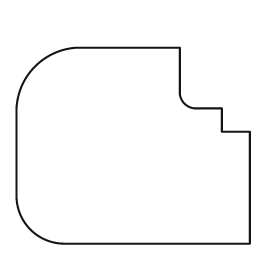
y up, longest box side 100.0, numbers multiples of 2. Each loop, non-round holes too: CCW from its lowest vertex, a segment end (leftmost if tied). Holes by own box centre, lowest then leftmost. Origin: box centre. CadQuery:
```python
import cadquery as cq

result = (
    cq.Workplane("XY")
    .moveTo(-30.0, -42.0)
    .lineTo(50.0, -42.0)
    .lineTo(50.0, 6.0)
    .lineTo(38.0, 6.0)
    .lineTo(38.0, 16.0)
    .lineTo(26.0, 16.0)
    .threePointArc((22.0, 18.0), (20.0, 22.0))
    .lineTo(20.0, 42.0)
    .lineTo(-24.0, 42.0)
    .threePointArc((-42.0, 34.0), (-50.0, 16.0))
    .lineTo(-50.0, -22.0)
    .threePointArc((-44.0, -36.0), (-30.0, -42.0))
    .close()
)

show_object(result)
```